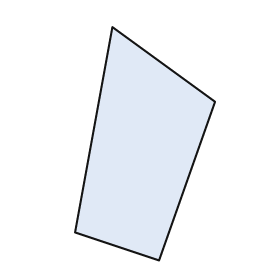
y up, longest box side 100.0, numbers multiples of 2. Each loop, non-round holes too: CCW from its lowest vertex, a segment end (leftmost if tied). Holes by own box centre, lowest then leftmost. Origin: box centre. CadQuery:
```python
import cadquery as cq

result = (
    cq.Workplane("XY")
    .moveTo(6.0, -50.0)
    .lineTo(30.0, 18.0)
    .lineTo(-14.0, 50.0)
    .lineTo(-30.0, -38.0)
    .close()
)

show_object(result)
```